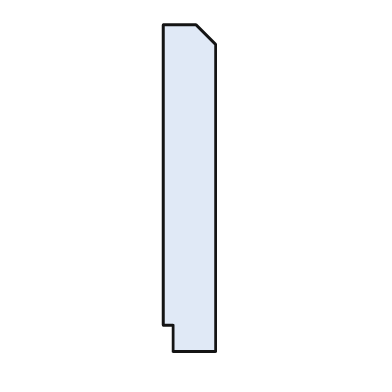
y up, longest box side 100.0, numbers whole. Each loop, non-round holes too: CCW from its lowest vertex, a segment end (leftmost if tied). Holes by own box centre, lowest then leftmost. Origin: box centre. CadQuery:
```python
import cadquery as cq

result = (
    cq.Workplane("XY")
    .moveTo(-5.0, -50.0)
    .lineTo(8.0, -50.0)
    .lineTo(8.0, 44.0)
    .lineTo(2.0, 50.0)
    .lineTo(-8.0, 50.0)
    .lineTo(-8.0, -42.0)
    .lineTo(-5.0, -42.0)
    .close()
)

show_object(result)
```